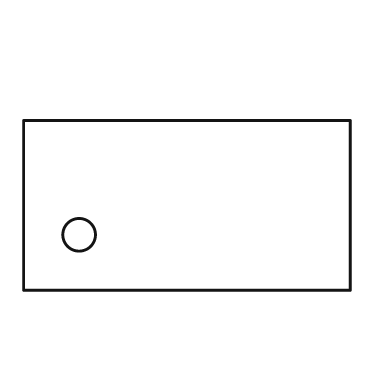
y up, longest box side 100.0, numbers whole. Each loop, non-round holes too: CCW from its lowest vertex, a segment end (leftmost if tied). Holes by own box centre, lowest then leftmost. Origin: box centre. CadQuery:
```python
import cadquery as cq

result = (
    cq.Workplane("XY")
    .moveTo(-50.0, -26.0)
    .lineTo(50.0, -26.0)
    .lineTo(50.0, 26.0)
    .lineTo(-50.0, 26.0)
    .close()
    .moveTo(-33.0, -9.0)
    .circle(5.0)
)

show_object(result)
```